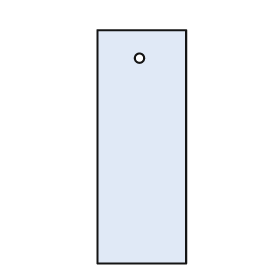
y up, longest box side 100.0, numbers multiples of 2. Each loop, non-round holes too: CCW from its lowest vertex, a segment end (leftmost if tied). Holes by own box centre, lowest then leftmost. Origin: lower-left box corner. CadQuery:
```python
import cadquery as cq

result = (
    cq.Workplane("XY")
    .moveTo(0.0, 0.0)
    .lineTo(38.0, 0.0)
    .lineTo(38.0, 100.0)
    .lineTo(0.0, 100.0)
    .close()
    .moveTo(18.0, 88.0)
    .circle(2.0)
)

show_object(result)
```